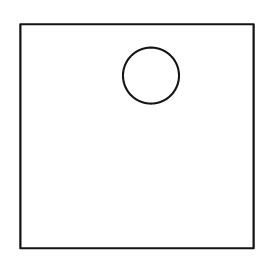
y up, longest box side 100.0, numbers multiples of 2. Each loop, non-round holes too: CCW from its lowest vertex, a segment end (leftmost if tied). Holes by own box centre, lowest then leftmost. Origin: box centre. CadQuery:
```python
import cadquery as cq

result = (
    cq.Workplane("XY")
    .moveTo(-50.0, -48.0)
    .lineTo(50.0, -48.0)
    .lineTo(50.0, 48.0)
    .lineTo(-50.0, 48.0)
    .close()
    .moveTo(6.0, 26.0)
    .circle(12.0)
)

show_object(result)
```